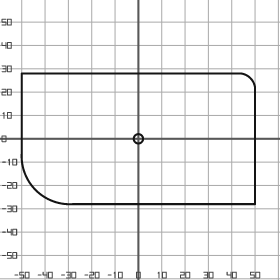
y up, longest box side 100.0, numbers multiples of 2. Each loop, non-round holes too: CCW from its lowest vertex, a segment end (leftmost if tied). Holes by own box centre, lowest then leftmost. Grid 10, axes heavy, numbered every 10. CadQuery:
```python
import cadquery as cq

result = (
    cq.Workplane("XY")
    .moveTo(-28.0, -28.0)
    .lineTo(50.0, -28.0)
    .lineTo(50.0, 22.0)
    .threePointArc((48.0, 26.0), (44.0, 28.0))
    .lineTo(-50.0, 28.0)
    .lineTo(-50.0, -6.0)
    .threePointArc((-44.0, -22.0), (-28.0, -28.0))
    .close()
    .moveTo(0.0, 0.0)
    .circle(2.0)
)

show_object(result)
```